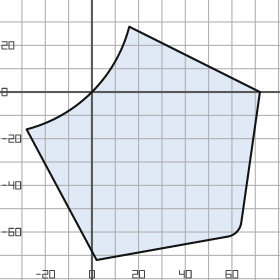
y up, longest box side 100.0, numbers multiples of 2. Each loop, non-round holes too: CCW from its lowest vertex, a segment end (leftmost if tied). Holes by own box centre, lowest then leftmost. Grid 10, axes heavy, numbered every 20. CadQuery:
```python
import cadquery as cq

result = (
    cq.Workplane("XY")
    .moveTo(2.0, -72.0)
    .lineTo(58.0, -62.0)
    .threePointArc((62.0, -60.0), (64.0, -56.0))
    .lineTo(72.0, 0.0)
    .lineTo(16.0, 28.0)
    .threePointArc((0.0, 0.0), (-28.0, -16.0))
    .close()
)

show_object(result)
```